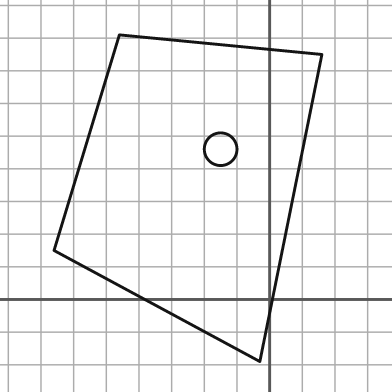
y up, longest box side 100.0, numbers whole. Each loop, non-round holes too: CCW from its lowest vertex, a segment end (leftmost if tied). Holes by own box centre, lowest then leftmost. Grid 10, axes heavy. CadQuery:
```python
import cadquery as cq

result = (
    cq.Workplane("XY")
    .moveTo(-3.0, -19.0)
    .lineTo(16.0, 75.0)
    .lineTo(-46.0, 81.0)
    .lineTo(-66.0, 15.0)
    .close()
    .moveTo(-15.0, 46.0)
    .circle(5.0)
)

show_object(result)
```